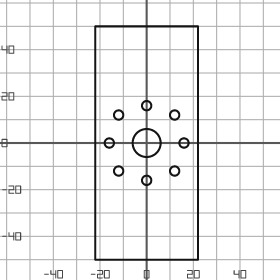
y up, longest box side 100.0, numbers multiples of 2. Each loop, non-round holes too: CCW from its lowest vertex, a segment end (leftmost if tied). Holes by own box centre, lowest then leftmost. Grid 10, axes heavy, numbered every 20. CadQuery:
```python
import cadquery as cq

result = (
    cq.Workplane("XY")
    .moveTo(-22.0, -50.0)
    .lineTo(22.0, -50.0)
    .lineTo(22.0, 50.0)
    .lineTo(-22.0, 50.0)
    .close()
    .moveTo(0.0, -16.0)
    .circle(2.0)
    .moveTo(-12.0, -12.0)
    .circle(2.0)
    .moveTo(12.0, -12.0)
    .circle(2.0)
    .moveTo(-16.0, 0.0)
    .circle(2.0)
    .moveTo(0.0, 0.0)
    .circle(6.0)
    .moveTo(16.0, 0.0)
    .circle(2.0)
    .moveTo(-12.0, 12.0)
    .circle(2.0)
    .moveTo(12.0, 12.0)
    .circle(2.0)
    .moveTo(0.0, 16.0)
    .circle(2.0)
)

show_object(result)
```